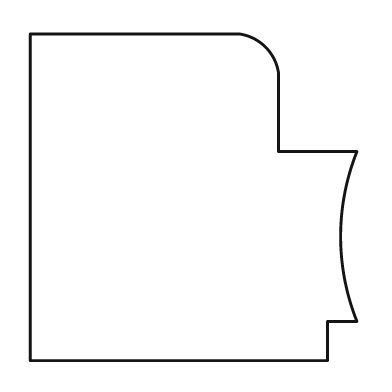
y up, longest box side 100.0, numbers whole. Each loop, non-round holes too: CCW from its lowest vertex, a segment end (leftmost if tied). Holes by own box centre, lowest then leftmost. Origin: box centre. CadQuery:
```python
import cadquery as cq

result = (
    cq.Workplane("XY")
    .moveTo(-50.0, -50.0)
    .lineTo(41.0, -50.0)
    .lineTo(41.0, -38.0)
    .lineTo(50.0, -38.0)
    .threePointArc((45.0, -12.0), (50.0, 14.0))
    .lineTo(26.0, 14.0)
    .lineTo(26.0, 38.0)
    .threePointArc((22.0, 46.0), (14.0, 50.0))
    .lineTo(-50.0, 50.0)
    .close()
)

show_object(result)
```